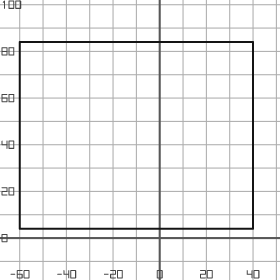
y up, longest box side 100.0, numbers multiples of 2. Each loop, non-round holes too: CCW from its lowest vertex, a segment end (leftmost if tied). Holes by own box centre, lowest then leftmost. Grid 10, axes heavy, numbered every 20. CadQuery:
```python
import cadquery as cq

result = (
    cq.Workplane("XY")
    .moveTo(-60.0, 4.0)
    .lineTo(40.0, 4.0)
    .lineTo(40.0, 84.0)
    .lineTo(-60.0, 84.0)
    .close()
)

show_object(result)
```